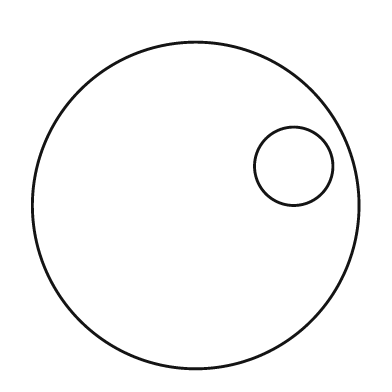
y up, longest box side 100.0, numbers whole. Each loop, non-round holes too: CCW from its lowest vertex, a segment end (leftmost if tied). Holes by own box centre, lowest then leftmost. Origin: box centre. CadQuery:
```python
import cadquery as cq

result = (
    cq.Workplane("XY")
    .moveTo(0.0, 0.0)
    .circle(50.0)
    .moveTo(30.0, 12.0)
    .circle(12.0)
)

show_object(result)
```